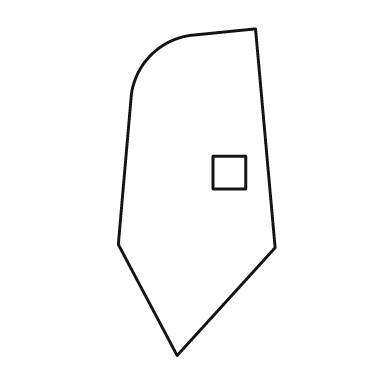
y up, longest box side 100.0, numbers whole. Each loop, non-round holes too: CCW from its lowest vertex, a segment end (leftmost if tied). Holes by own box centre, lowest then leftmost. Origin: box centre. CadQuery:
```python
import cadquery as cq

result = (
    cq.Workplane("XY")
    .moveTo(-6.0, -50.0)
    .lineTo(24.0, -17.0)
    .lineTo(18.0, 50.0)
    .lineTo(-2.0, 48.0)
    .threePointArc((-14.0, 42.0), (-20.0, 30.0))
    .lineTo(-24.0, -16.0)
    .close()
    .moveTo(5.0, 1.0)
    .lineTo(15.0, 1.0)
    .lineTo(15.0, 11.0)
    .lineTo(5.0, 11.0)
    .close()
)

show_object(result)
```